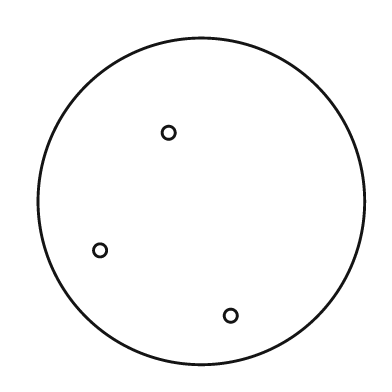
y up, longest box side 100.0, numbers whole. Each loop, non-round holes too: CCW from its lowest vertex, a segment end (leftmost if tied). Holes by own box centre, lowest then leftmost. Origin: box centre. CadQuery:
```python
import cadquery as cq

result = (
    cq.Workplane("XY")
    .moveTo(0.0, 0.0)
    .circle(50.0)
    .moveTo(9.0, -35.0)
    .circle(2.0)
    .moveTo(-31.0, -15.0)
    .circle(2.0)
    .moveTo(-10.0, 21.0)
    .circle(2.0)
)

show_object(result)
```